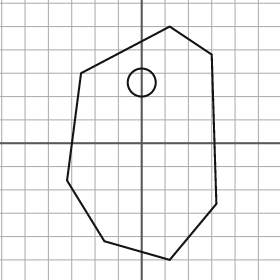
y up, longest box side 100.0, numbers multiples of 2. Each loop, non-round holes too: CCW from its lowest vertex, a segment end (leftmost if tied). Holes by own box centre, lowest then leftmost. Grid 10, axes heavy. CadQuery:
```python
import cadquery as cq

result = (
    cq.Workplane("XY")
    .moveTo(12.0, -50.0)
    .lineTo(32.0, -26.0)
    .lineTo(30.0, 38.0)
    .lineTo(12.0, 50.0)
    .lineTo(-26.0, 30.0)
    .lineTo(-32.0, -16.0)
    .lineTo(-16.0, -42.0)
    .close()
    .moveTo(0.0, 26.0)
    .circle(6.0)
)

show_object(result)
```